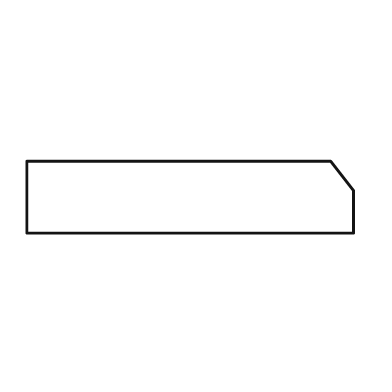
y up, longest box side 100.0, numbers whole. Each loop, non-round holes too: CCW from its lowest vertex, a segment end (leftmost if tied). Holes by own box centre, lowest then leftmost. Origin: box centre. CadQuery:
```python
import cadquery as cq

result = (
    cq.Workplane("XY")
    .moveTo(-50.0, -11.0)
    .lineTo(50.0, -11.0)
    .lineTo(50.0, 2.0)
    .lineTo(43.0, 11.0)
    .lineTo(-50.0, 11.0)
    .close()
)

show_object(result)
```